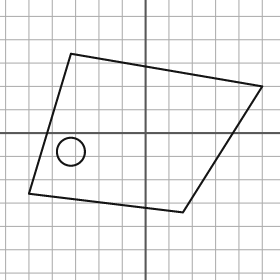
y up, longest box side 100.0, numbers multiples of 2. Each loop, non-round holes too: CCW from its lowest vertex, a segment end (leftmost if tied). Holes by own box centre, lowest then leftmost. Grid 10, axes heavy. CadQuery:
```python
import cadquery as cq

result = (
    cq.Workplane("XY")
    .moveTo(16.0, -34.0)
    .lineTo(50.0, 20.0)
    .lineTo(-32.0, 34.0)
    .lineTo(-50.0, -26.0)
    .close()
    .moveTo(-32.0, -8.0)
    .circle(6.0)
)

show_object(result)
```